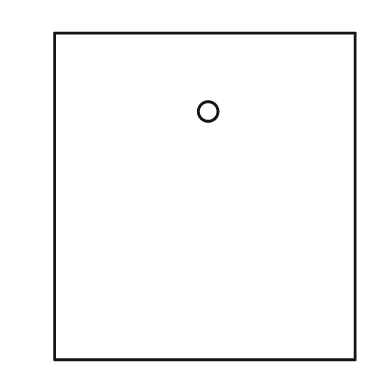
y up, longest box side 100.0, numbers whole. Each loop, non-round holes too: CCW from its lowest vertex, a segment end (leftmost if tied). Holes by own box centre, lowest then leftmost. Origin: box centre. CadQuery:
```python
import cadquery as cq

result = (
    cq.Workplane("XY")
    .moveTo(-46.0, -50.0)
    .lineTo(46.0, -50.0)
    .lineTo(46.0, 50.0)
    .lineTo(-46.0, 50.0)
    .close()
    .moveTo(1.0, 26.0)
    .circle(3.0)
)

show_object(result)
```